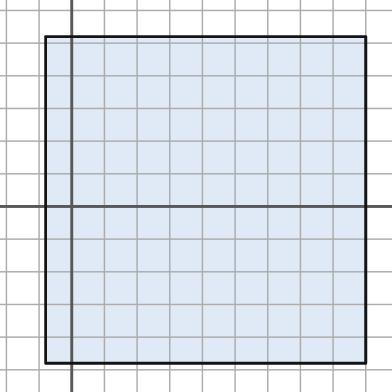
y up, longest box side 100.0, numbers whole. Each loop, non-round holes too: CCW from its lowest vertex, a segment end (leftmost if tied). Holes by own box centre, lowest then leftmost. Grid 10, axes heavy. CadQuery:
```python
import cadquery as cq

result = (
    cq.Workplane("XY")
    .moveTo(-8.0, -48.0)
    .lineTo(90.0, -48.0)
    .lineTo(90.0, 52.0)
    .lineTo(-8.0, 52.0)
    .close()
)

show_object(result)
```